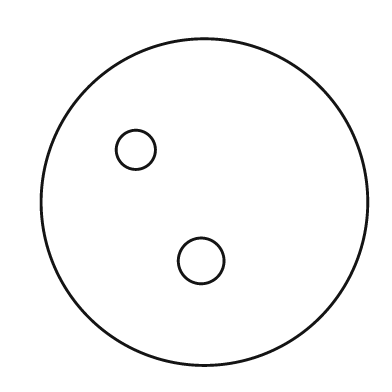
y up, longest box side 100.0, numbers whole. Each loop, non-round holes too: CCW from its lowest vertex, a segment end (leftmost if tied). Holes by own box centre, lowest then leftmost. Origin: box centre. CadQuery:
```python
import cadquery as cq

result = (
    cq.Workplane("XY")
    .moveTo(0.0, 0.0)
    .circle(50.0)
    .moveTo(-1.0, -18.0)
    .circle(7.0)
    .moveTo(-21.0, 16.0)
    .circle(6.0)
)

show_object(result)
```